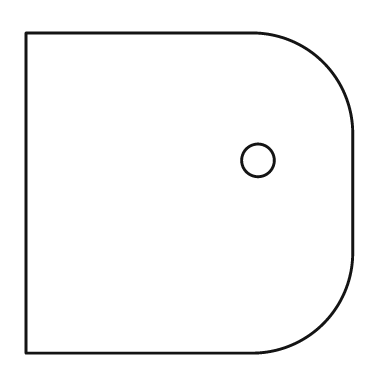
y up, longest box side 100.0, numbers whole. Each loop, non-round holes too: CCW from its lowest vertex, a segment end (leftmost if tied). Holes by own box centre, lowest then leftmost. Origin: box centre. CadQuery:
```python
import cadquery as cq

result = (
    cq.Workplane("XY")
    .moveTo(-50.0, -49.0)
    .lineTo(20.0, -49.0)
    .threePointArc((41.0, -40.0), (50.0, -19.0))
    .lineTo(50.0, 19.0)
    .threePointArc((41.0, 40.0), (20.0, 49.0))
    .lineTo(-50.0, 49.0)
    .close()
    .moveTo(21.0, 10.0)
    .circle(5.0)
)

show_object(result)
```